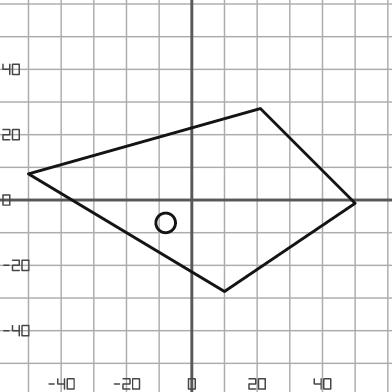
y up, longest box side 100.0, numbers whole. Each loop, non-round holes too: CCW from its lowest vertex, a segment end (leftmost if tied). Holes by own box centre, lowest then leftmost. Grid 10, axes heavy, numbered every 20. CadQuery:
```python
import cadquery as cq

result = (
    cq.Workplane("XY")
    .moveTo(10.0, -28.0)
    .lineTo(50.0, -1.0)
    .lineTo(21.0, 28.0)
    .lineTo(-50.0, 8.0)
    .close()
    .moveTo(-8.0, -7.0)
    .circle(3.0)
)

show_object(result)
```